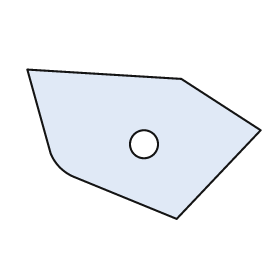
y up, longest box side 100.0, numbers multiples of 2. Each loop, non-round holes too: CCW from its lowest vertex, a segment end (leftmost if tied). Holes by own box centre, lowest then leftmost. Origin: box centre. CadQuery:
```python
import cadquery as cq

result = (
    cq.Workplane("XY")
    .moveTo(14.0, -32.0)
    .lineTo(50.0, 6.0)
    .lineTo(16.0, 28.0)
    .lineTo(-50.0, 32.0)
    .lineTo(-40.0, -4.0)
    .threePointArc((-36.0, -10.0), (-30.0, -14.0))
    .close()
    .moveTo(0.0, 0.0)
    .circle(6.0)
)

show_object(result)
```